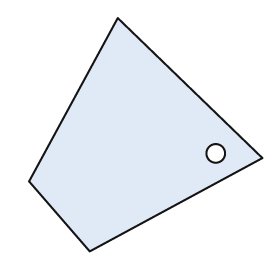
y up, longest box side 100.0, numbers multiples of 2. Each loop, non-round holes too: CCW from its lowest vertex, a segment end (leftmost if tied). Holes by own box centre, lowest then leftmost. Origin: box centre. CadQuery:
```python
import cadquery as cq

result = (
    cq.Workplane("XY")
    .moveTo(-24.0, -50.0)
    .lineTo(50.0, -10.0)
    .lineTo(-12.0, 50.0)
    .lineTo(-50.0, -20.0)
    .close()
    .moveTo(30.0, -8.0)
    .circle(4.0)
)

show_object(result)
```